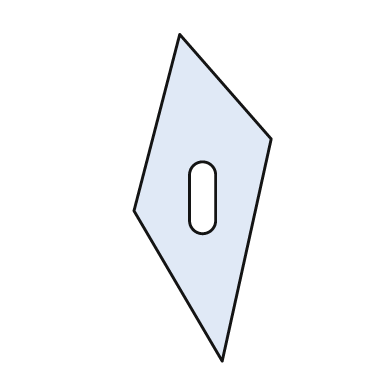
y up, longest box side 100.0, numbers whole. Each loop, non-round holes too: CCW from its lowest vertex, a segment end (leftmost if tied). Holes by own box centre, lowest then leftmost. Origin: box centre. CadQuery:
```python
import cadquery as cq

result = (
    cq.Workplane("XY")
    .moveTo(6.0, -50.0)
    .lineTo(21.0, 18.0)
    .lineTo(-7.0, 50.0)
    .lineTo(-21.0, -4.0)
    .close()
    .moveTo(-4.0, -7.0)
    .threePointArc((0.0, -11.0), (4.0, -7.0))
    .lineTo(4.0, 7.0)
    .threePointArc((0.0, 11.0), (-4.0, 7.0))
    .close()
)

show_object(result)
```